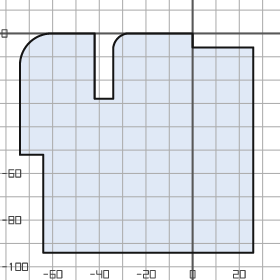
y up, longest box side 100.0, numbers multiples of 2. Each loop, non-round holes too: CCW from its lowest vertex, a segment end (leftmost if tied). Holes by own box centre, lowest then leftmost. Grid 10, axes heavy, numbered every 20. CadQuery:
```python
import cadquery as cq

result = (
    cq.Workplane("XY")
    .moveTo(-64.0, -94.0)
    .lineTo(26.0, -94.0)
    .lineTo(26.0, -6.0)
    .lineTo(0.0, -6.0)
    .lineTo(0.0, 0.0)
    .lineTo(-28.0, 0.0)
    .threePointArc((-32.0, -2.0), (-34.0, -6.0))
    .lineTo(-34.0, -28.0)
    .lineTo(-42.0, -28.0)
    .lineTo(-42.0, 0.0)
    .lineTo(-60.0, 0.0)
    .threePointArc((-70.0, -4.0), (-74.0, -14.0))
    .lineTo(-74.0, -52.0)
    .lineTo(-64.0, -52.0)
    .close()
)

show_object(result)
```